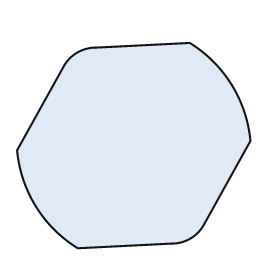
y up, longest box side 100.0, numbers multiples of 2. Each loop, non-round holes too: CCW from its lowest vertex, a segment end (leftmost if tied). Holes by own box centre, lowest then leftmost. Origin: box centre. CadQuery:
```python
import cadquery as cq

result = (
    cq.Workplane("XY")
    .moveTo(-24.0, -44.0)
    .lineTo(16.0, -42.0)
    .threePointArc((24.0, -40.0), (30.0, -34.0))
    .lineTo(50.0, 2.0)
    .threePointArc((42.0, 26.0), (24.0, 44.0))
    .lineTo(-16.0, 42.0)
    .threePointArc((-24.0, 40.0), (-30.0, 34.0))
    .lineTo(-50.0, -2.0)
    .threePointArc((-42.0, -26.0), (-24.0, -44.0))
    .close()
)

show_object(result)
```